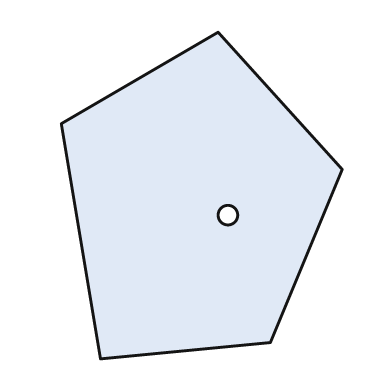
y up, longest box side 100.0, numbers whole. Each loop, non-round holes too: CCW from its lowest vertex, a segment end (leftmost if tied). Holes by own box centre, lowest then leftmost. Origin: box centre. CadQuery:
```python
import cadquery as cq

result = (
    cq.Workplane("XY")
    .moveTo(-31.0, -50.0)
    .lineTo(21.0, -45.0)
    .lineTo(43.0, 8.0)
    .lineTo(5.0, 50.0)
    .lineTo(-43.0, 22.0)
    .close()
    .moveTo(8.0, -6.0)
    .circle(3.0)
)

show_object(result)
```